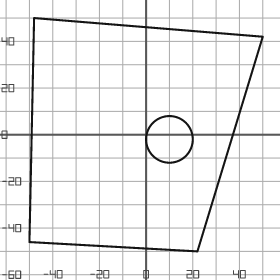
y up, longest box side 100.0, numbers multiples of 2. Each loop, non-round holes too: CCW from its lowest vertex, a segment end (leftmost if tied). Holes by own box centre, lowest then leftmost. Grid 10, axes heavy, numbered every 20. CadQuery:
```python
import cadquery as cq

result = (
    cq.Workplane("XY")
    .moveTo(22.0, -50.0)
    .lineTo(50.0, 42.0)
    .lineTo(-48.0, 50.0)
    .lineTo(-50.0, -46.0)
    .close()
    .moveTo(10.0, -2.0)
    .circle(10.0)
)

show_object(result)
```